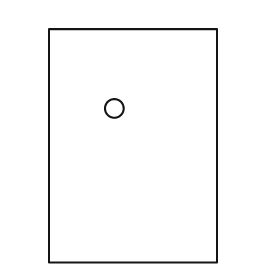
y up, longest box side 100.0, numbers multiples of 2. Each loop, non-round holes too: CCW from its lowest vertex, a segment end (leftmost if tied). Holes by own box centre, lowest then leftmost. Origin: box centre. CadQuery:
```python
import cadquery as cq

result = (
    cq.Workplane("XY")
    .moveTo(-36.0, -50.0)
    .lineTo(36.0, -50.0)
    .lineTo(36.0, 50.0)
    .lineTo(-36.0, 50.0)
    .close()
    .moveTo(-8.0, 16.0)
    .circle(4.0)
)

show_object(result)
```